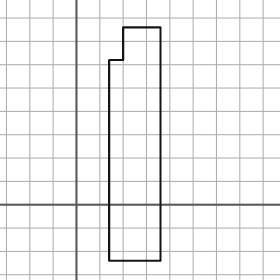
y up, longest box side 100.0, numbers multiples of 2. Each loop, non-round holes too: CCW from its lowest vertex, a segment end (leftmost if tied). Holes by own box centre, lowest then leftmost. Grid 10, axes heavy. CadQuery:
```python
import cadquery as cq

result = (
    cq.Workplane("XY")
    .moveTo(14.0, -24.0)
    .lineTo(36.0, -24.0)
    .lineTo(36.0, 76.0)
    .lineTo(20.0, 76.0)
    .lineTo(20.0, 62.0)
    .lineTo(14.0, 62.0)
    .close()
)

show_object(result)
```